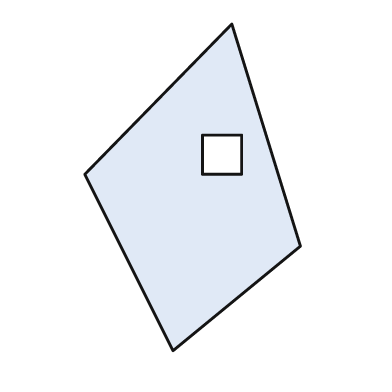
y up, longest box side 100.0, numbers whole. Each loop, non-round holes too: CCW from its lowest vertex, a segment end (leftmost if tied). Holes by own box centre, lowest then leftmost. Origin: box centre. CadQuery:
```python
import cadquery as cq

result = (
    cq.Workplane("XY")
    .moveTo(-6.0, -50.0)
    .lineTo(33.0, -18.0)
    .lineTo(12.0, 50.0)
    .lineTo(-33.0, 4.0)
    .close()
    .moveTo(3.0, 4.0)
    .lineTo(15.0, 4.0)
    .lineTo(15.0, 16.0)
    .lineTo(3.0, 16.0)
    .close()
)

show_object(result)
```